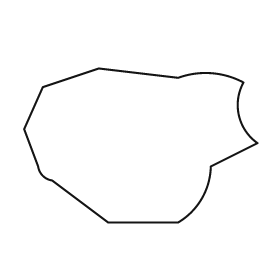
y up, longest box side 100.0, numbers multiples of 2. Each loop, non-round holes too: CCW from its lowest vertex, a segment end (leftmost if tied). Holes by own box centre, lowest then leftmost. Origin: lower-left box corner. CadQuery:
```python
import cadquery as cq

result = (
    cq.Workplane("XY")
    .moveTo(36.0, 0.0)
    .lineTo(66.0, 0.0)
    .threePointArc((76.0, 10.0), (80.0, 24.0))
    .lineTo(100.0, 34.0)
    .threePointArc((92.0, 46.0), (94.0, 60.0))
    .threePointArc((80.0, 64.0), (66.0, 62.0))
    .lineTo(32.0, 66.0)
    .lineTo(8.0, 58.0)
    .lineTo(0.0, 40.0)
    .lineTo(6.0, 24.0)
    .threePointArc((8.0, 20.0), (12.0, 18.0))
    .close()
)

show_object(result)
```